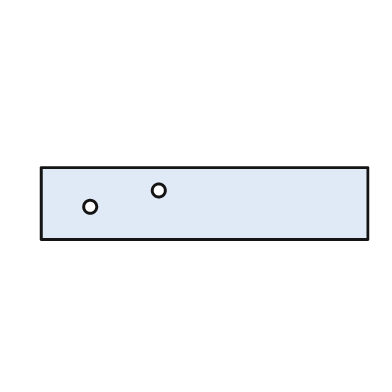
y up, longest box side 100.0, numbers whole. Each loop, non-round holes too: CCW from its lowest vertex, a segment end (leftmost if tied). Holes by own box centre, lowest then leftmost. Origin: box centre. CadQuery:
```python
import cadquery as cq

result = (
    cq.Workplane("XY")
    .moveTo(-50.0, -11.0)
    .lineTo(50.0, -11.0)
    .lineTo(50.0, 11.0)
    .lineTo(-50.0, 11.0)
    .close()
    .moveTo(-35.0, -1.0)
    .circle(2.0)
    .moveTo(-14.0, 4.0)
    .circle(2.0)
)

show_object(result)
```